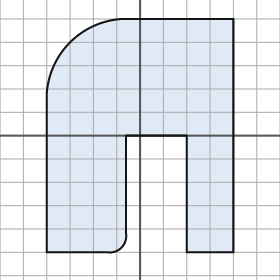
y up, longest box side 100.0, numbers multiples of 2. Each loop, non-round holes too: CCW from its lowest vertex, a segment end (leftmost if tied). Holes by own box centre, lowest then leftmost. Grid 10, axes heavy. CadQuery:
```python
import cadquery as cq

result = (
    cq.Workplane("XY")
    .moveTo(-40.0, -50.0)
    .lineTo(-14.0, -50.0)
    .threePointArc((-8.0, -48.0), (-6.0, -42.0))
    .lineTo(-6.0, 0.0)
    .lineTo(20.0, 0.0)
    .lineTo(20.0, -50.0)
    .lineTo(40.0, -50.0)
    .lineTo(40.0, 50.0)
    .lineTo(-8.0, 50.0)
    .threePointArc((-30.0, 40.0), (-40.0, 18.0))
    .close()
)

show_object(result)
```